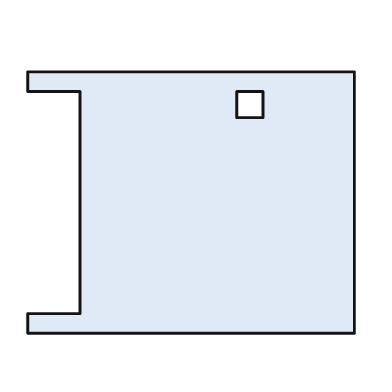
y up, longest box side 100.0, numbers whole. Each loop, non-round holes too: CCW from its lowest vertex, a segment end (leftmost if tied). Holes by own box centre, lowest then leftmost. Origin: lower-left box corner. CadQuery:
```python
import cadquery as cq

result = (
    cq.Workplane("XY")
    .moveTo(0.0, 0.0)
    .lineTo(100.0, 0.0)
    .lineTo(100.0, 80.0)
    .lineTo(0.0, 80.0)
    .lineTo(0.0, 74.0)
    .lineTo(16.0, 74.0)
    .lineTo(16.0, 6.0)
    .lineTo(0.0, 6.0)
    .close()
    .moveTo(64.0, 66.0)
    .lineTo(72.0, 66.0)
    .lineTo(72.0, 74.0)
    .lineTo(64.0, 74.0)
    .close()
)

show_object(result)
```